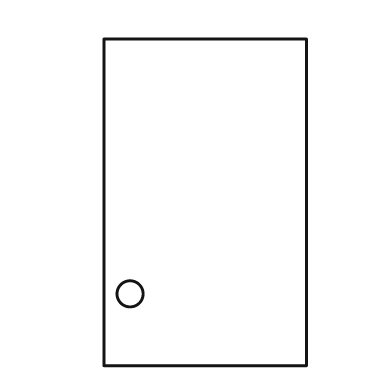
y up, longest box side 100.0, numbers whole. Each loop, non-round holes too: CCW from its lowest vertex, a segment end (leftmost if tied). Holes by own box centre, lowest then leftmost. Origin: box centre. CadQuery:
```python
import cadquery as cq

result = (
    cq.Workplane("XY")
    .moveTo(-31.0, -50.0)
    .lineTo(31.0, -50.0)
    .lineTo(31.0, 50.0)
    .lineTo(-31.0, 50.0)
    .close()
    .moveTo(-23.0, -28.0)
    .circle(4.0)
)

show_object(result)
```